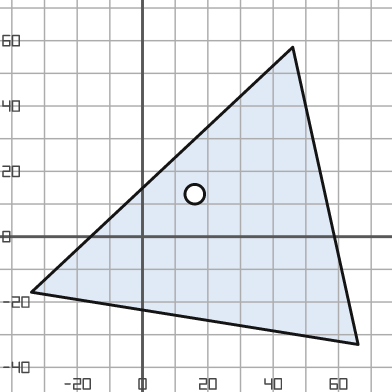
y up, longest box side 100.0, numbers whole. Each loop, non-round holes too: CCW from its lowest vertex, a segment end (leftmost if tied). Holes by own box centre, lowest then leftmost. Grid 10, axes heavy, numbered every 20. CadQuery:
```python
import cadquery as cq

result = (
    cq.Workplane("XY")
    .moveTo(66.0, -33.0)
    .lineTo(46.0, 58.0)
    .lineTo(-34.0, -17.0)
    .close()
    .moveTo(16.0, 13.0)
    .circle(3.0)
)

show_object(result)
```